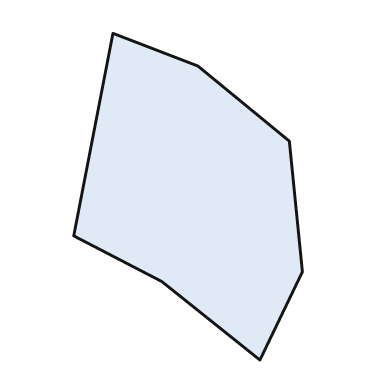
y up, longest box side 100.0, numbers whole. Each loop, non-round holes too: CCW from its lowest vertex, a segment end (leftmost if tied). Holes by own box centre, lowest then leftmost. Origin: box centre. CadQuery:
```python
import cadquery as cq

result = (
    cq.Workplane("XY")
    .moveTo(22.0, -50.0)
    .lineTo(35.0, -23.0)
    .lineTo(31.0, 17.0)
    .lineTo(3.0, 40.0)
    .lineTo(-23.0, 50.0)
    .lineTo(-35.0, -12.0)
    .lineTo(-8.0, -26.0)
    .close()
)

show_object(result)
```